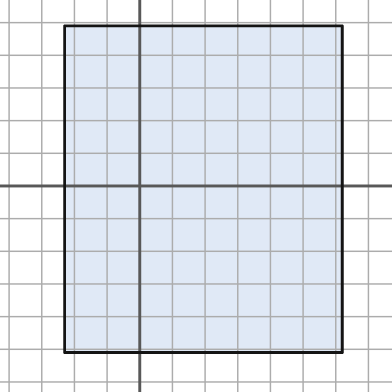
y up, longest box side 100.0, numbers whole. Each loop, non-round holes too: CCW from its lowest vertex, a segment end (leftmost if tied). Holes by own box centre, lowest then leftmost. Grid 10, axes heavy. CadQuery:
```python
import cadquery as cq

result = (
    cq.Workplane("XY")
    .moveTo(-23.0, -51.0)
    .lineTo(62.0, -51.0)
    .lineTo(62.0, 49.0)
    .lineTo(-23.0, 49.0)
    .close()
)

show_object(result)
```